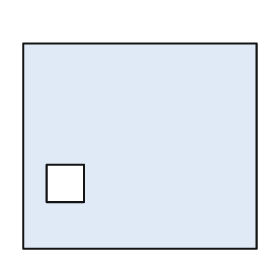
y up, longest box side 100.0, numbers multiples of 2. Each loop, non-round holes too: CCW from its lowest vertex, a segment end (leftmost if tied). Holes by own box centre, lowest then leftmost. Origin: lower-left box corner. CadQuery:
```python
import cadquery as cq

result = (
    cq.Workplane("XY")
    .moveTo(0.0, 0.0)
    .lineTo(100.0, 0.0)
    .lineTo(100.0, 88.0)
    .lineTo(0.0, 88.0)
    .close()
    .moveTo(10.0, 20.0)
    .lineTo(26.0, 20.0)
    .lineTo(26.0, 36.0)
    .lineTo(10.0, 36.0)
    .close()
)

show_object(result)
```